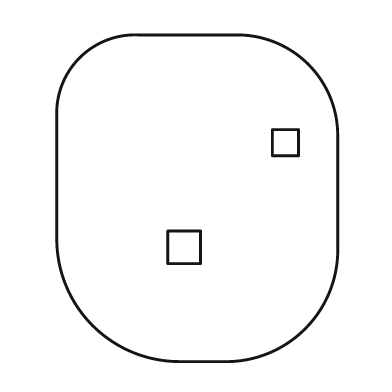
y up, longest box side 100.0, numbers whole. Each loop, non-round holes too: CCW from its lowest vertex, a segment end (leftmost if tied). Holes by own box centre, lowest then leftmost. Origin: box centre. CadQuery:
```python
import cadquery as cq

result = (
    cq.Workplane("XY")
    .moveTo(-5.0, -50.0)
    .lineTo(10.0, -50.0)
    .threePointArc((33.0, -40.0), (43.0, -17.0))
    .lineTo(43.0, 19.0)
    .threePointArc((34.0, 41.0), (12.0, 50.0))
    .lineTo(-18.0, 50.0)
    .threePointArc((-36.0, 43.0), (-43.0, 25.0))
    .lineTo(-43.0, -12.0)
    .threePointArc((-32.0, -39.0), (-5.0, -50.0))
    .close()
    .moveTo(-9.0, -20.0)
    .lineTo(1.0, -20.0)
    .lineTo(1.0, -10.0)
    .lineTo(-9.0, -10.0)
    .close()
    .moveTo(23.0, 13.0)
    .lineTo(31.0, 13.0)
    .lineTo(31.0, 21.0)
    .lineTo(23.0, 21.0)
    .close()
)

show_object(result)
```